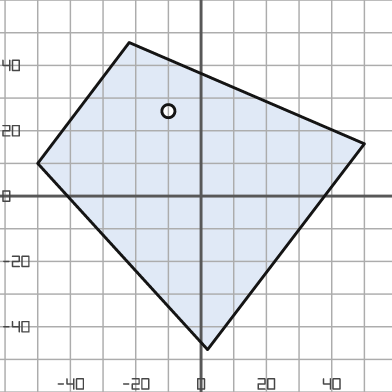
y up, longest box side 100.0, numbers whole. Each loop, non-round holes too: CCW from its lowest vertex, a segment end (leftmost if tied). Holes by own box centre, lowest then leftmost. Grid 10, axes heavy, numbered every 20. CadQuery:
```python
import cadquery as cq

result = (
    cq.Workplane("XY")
    .moveTo(2.0, -47.0)
    .lineTo(50.0, 16.0)
    .lineTo(-22.0, 47.0)
    .lineTo(-50.0, 10.0)
    .close()
    .moveTo(-10.0, 26.0)
    .circle(2.0)
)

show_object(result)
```